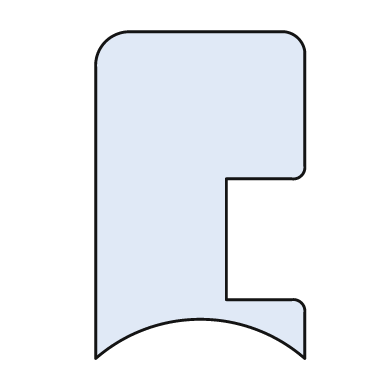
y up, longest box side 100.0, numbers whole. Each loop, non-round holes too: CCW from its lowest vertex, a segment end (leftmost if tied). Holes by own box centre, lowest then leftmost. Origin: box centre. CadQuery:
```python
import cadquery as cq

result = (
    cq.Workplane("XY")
    .moveTo(-32.0, -50.0)
    .threePointArc((0.0, -38.0), (32.0, -50.0))
    .lineTo(32.0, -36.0)
    .threePointArc((31.0, -33.0), (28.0, -32.0))
    .lineTo(8.0, -32.0)
    .lineTo(8.0, 5.0)
    .lineTo(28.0, 5.0)
    .threePointArc((31.0, 6.0), (32.0, 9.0))
    .lineTo(32.0, 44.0)
    .threePointArc((30.0, 48.0), (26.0, 50.0))
    .lineTo(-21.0, 50.0)
    .threePointArc((-29.0, 47.0), (-32.0, 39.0))
    .close()
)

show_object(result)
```